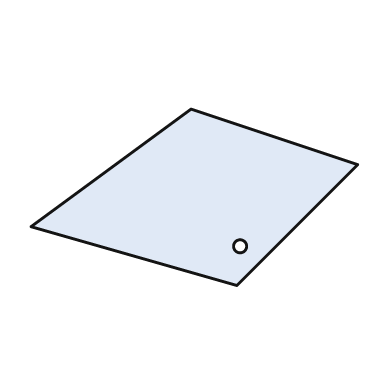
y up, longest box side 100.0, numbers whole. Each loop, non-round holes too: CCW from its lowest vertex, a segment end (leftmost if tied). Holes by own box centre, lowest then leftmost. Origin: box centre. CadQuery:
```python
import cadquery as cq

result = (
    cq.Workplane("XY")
    .moveTo(13.0, -27.0)
    .lineTo(50.0, 10.0)
    .lineTo(-1.0, 27.0)
    .lineTo(-50.0, -9.0)
    .close()
    .moveTo(14.0, -15.0)
    .circle(2.0)
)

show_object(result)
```